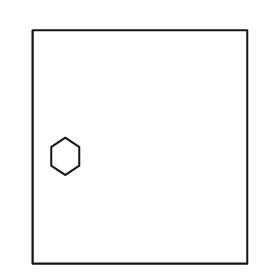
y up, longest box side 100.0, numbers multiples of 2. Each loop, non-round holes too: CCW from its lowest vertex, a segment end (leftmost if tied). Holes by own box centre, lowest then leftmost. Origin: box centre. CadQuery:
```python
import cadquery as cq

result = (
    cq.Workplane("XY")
    .moveTo(-46.0, -50.0)
    .lineTo(46.0, -50.0)
    .lineTo(46.0, 50.0)
    .lineTo(-46.0, 50.0)
    .close()
    .moveTo(-32.0, -12.0)
    .lineTo(-26.0, -8.0)
    .lineTo(-26.0, 0.0)
    .lineTo(-32.0, 4.0)
    .lineTo(-38.0, 0.0)
    .lineTo(-38.0, -8.0)
    .close()
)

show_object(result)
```